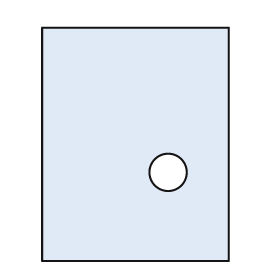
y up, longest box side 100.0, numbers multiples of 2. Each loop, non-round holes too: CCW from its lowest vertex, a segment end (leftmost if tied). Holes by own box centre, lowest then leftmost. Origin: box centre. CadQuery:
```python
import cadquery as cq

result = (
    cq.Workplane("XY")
    .moveTo(-40.0, -50.0)
    .lineTo(40.0, -50.0)
    .lineTo(40.0, 50.0)
    .lineTo(-40.0, 50.0)
    .close()
    .moveTo(14.0, -12.0)
    .circle(8.0)
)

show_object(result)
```